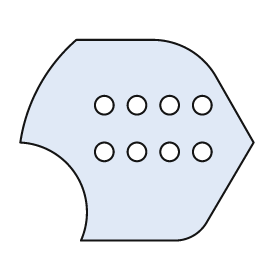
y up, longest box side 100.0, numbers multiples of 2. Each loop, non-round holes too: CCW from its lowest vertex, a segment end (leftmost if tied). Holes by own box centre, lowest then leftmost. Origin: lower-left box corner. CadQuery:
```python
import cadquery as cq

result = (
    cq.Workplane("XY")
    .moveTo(26.0, 0.0)
    .lineTo(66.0, 0.0)
    .threePointArc((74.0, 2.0), (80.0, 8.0))
    .lineTo(100.0, 42.0)
    .lineTo(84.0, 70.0)
    .threePointArc((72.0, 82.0), (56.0, 86.0))
    .lineTo(24.0, 86.0)
    .threePointArc((8.0, 66.0), (0.0, 42.0))
    .threePointArc((24.0, 28.0), (26.0, 0.0))
    .close()
    .moveTo(36.0, 38.0)
    .circle(4.0)
    .moveTo(50.0, 38.0)
    .circle(4.0)
    .moveTo(64.0, 38.0)
    .circle(4.0)
    .moveTo(78.0, 38.0)
    .circle(4.0)
    .moveTo(36.0, 58.0)
    .circle(4.0)
    .moveTo(50.0, 58.0)
    .circle(4.0)
    .moveTo(64.0, 58.0)
    .circle(4.0)
    .moveTo(78.0, 58.0)
    .circle(4.0)
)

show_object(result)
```